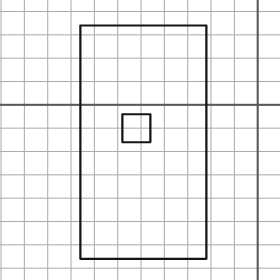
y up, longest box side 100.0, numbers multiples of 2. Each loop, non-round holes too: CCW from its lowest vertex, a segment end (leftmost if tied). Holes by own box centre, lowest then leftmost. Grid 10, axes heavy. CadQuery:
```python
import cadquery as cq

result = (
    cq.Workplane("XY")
    .moveTo(-76.0, -66.0)
    .lineTo(-22.0, -66.0)
    .lineTo(-22.0, 34.0)
    .lineTo(-76.0, 34.0)
    .close()
    .moveTo(-58.0, -16.0)
    .lineTo(-46.0, -16.0)
    .lineTo(-46.0, -4.0)
    .lineTo(-58.0, -4.0)
    .close()
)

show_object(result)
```